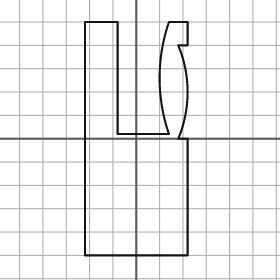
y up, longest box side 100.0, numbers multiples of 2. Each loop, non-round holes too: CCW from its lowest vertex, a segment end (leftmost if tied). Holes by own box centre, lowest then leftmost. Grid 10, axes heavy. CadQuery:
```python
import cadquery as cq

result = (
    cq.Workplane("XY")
    .moveTo(-22.0, -50.0)
    .lineTo(22.0, -50.0)
    .lineTo(22.0, 0.0)
    .lineTo(18.0, 0.0)
    .threePointArc((22.0, 20.0), (18.0, 40.0))
    .lineTo(22.0, 40.0)
    .lineTo(22.0, 50.0)
    .lineTo(14.0, 50.0)
    .threePointArc((10.0, 26.0), (14.0, 2.0))
    .lineTo(-8.0, 2.0)
    .lineTo(-8.0, 50.0)
    .lineTo(-22.0, 50.0)
    .close()
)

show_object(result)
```